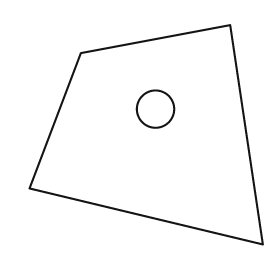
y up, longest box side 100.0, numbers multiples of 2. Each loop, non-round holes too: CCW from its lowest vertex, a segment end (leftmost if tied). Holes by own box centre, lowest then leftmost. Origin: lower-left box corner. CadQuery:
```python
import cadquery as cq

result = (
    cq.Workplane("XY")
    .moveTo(100.0, 0.0)
    .lineTo(86.0, 94.0)
    .lineTo(22.0, 82.0)
    .lineTo(0.0, 24.0)
    .close()
    .moveTo(54.0, 58.0)
    .circle(8.0)
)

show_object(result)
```